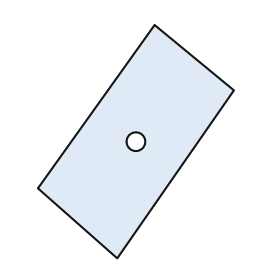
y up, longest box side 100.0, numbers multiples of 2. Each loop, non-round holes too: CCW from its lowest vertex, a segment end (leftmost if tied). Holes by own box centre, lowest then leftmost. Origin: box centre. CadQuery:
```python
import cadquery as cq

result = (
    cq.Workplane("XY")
    .moveTo(-8.0, -50.0)
    .lineTo(42.0, 22.0)
    .lineTo(8.0, 50.0)
    .lineTo(-42.0, -20.0)
    .close()
    .moveTo(0.0, 0.0)
    .circle(4.0)
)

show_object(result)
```